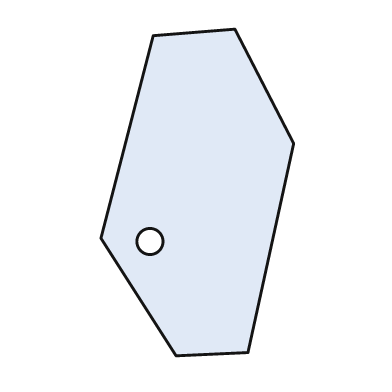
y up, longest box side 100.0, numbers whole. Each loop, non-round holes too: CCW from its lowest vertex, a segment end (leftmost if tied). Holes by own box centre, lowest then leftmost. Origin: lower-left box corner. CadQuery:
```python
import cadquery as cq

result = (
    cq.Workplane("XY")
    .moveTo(23.0, 0.0)
    .lineTo(45.0, 1.0)
    .lineTo(59.0, 65.0)
    .lineTo(41.0, 100.0)
    .lineTo(16.0, 98.0)
    .lineTo(0.0, 36.0)
    .close()
    .moveTo(15.0, 35.0)
    .circle(4.0)
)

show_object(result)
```